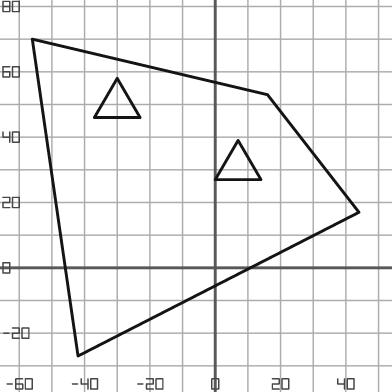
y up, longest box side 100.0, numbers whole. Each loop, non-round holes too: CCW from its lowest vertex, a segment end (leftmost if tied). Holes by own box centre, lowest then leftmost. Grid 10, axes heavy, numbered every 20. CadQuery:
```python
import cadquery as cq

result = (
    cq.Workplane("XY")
    .moveTo(-42.0, -27.0)
    .lineTo(44.0, 17.0)
    .lineTo(16.0, 53.0)
    .lineTo(-56.0, 70.0)
    .close()
    .moveTo(0.0, 27.0)
    .lineTo(14.0, 27.0)
    .lineTo(7.0, 39.0)
    .close()
    .moveTo(-37.0, 46.0)
    .lineTo(-23.0, 46.0)
    .lineTo(-30.0, 58.0)
    .close()
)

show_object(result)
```